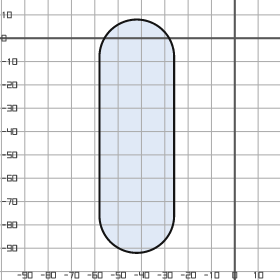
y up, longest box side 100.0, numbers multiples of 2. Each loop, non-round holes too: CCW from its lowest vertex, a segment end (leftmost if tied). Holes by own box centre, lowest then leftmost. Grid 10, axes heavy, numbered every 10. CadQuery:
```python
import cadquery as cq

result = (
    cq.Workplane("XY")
    .moveTo(-58.0, -76.0)
    .threePointArc((-42.0, -92.0), (-26.0, -76.0))
    .lineTo(-26.0, -8.0)
    .threePointArc((-42.0, 8.0), (-58.0, -8.0))
    .close()
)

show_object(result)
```